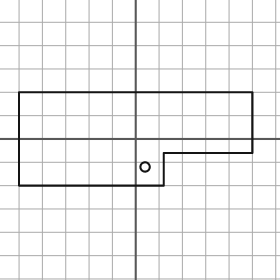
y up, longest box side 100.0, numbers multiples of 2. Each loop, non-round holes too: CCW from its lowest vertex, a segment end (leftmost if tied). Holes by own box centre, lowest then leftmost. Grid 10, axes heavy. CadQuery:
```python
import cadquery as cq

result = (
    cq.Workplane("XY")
    .moveTo(-50.0, -20.0)
    .lineTo(12.0, -20.0)
    .lineTo(12.0, -6.0)
    .lineTo(50.0, -6.0)
    .lineTo(50.0, 20.0)
    .lineTo(-50.0, 20.0)
    .close()
    .moveTo(4.0, -12.0)
    .circle(2.0)
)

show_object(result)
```